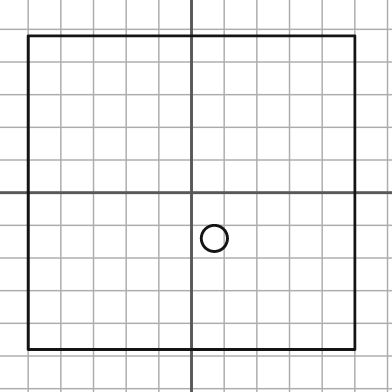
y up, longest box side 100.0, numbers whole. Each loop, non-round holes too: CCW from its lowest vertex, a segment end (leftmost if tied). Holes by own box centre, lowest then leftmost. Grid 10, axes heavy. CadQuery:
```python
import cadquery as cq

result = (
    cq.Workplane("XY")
    .moveTo(-50.0, -48.0)
    .lineTo(50.0, -48.0)
    .lineTo(50.0, 48.0)
    .lineTo(-50.0, 48.0)
    .close()
    .moveTo(7.0, -14.0)
    .circle(4.0)
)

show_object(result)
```